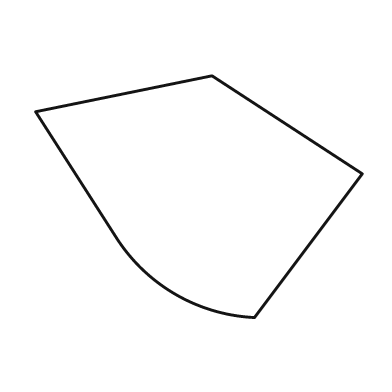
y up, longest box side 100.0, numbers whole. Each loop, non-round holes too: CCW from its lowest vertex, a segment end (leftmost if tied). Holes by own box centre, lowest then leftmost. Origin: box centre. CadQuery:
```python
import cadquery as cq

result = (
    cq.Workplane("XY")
    .moveTo(17.0, -37.0)
    .lineTo(50.0, 7.0)
    .lineTo(4.0, 37.0)
    .lineTo(-50.0, 26.0)
    .lineTo(-25.0, -13.0)
    .threePointArc((-7.0, -30.0), (17.0, -37.0))
    .close()
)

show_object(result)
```